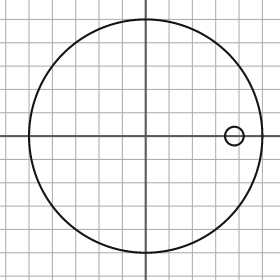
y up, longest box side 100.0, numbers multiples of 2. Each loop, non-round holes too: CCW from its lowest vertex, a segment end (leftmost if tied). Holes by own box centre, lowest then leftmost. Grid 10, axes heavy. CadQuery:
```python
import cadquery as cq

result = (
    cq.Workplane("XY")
    .moveTo(0.0, 0.0)
    .circle(50.0)
    .moveTo(38.0, 0.0)
    .circle(4.0)
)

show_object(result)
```